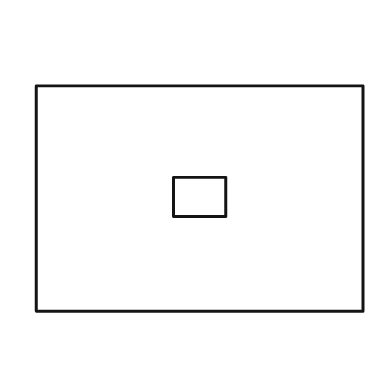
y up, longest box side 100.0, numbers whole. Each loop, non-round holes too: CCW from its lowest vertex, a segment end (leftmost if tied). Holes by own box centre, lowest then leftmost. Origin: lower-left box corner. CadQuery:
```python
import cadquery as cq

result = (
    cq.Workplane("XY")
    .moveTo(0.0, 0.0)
    .lineTo(100.0, 0.0)
    .lineTo(100.0, 69.0)
    .lineTo(0.0, 69.0)
    .close()
    .moveTo(42.0, 29.0)
    .lineTo(58.0, 29.0)
    .lineTo(58.0, 41.0)
    .lineTo(42.0, 41.0)
    .close()
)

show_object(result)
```